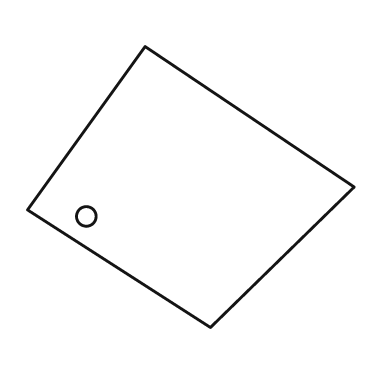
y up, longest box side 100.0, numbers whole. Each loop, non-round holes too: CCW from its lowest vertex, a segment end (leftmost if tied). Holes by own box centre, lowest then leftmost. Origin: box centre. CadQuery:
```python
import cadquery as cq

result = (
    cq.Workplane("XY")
    .moveTo(6.0, -43.0)
    .lineTo(50.0, 0.0)
    .lineTo(-14.0, 43.0)
    .lineTo(-50.0, -7.0)
    .close()
    .moveTo(-32.0, -9.0)
    .circle(3.0)
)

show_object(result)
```